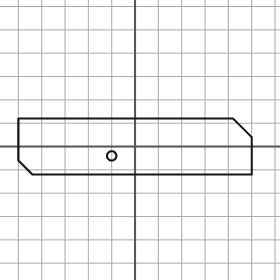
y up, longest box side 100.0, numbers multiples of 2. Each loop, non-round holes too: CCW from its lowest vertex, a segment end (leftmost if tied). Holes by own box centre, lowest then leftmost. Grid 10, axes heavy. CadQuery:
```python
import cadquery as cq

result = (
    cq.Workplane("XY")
    .moveTo(-44.0, -12.0)
    .lineTo(50.0, -12.0)
    .lineTo(50.0, 4.0)
    .lineTo(42.0, 12.0)
    .lineTo(-50.0, 12.0)
    .lineTo(-50.0, -6.0)
    .close()
    .moveTo(-10.0, -4.0)
    .circle(2.0)
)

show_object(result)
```